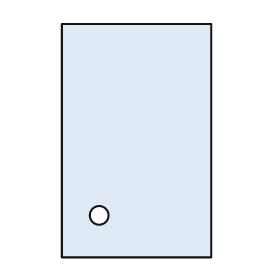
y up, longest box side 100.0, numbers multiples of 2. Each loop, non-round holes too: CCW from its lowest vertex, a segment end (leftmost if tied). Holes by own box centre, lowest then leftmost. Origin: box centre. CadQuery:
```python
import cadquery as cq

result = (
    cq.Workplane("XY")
    .moveTo(-32.0, -50.0)
    .lineTo(32.0, -50.0)
    .lineTo(32.0, 50.0)
    .lineTo(-32.0, 50.0)
    .close()
    .moveTo(-16.0, -32.0)
    .circle(4.0)
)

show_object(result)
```